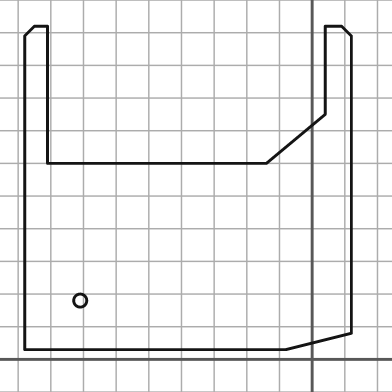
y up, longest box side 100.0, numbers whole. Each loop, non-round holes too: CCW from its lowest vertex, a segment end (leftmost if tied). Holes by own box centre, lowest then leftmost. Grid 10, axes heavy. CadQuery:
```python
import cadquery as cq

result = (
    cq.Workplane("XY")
    .moveTo(-88.0, 3.0)
    .lineTo(-8.0, 3.0)
    .lineTo(12.0, 8.0)
    .lineTo(12.0, 99.0)
    .lineTo(9.0, 102.0)
    .lineTo(4.0, 102.0)
    .lineTo(4.0, 75.0)
    .lineTo(-14.0, 60.0)
    .lineTo(-81.0, 60.0)
    .lineTo(-81.0, 102.0)
    .lineTo(-85.0, 102.0)
    .lineTo(-88.0, 99.0)
    .close()
    .moveTo(-71.0, 18.0)
    .circle(2.0)
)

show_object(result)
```